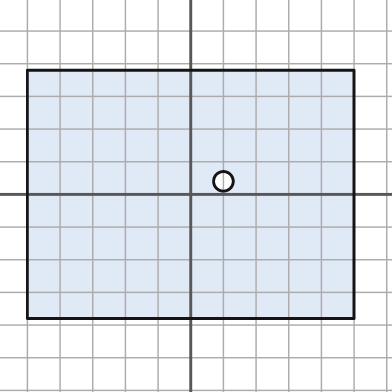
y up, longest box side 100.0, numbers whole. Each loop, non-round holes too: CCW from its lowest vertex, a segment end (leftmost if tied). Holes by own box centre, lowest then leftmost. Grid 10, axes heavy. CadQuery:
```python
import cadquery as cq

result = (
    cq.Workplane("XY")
    .moveTo(-50.0, -38.0)
    .lineTo(50.0, -38.0)
    .lineTo(50.0, 38.0)
    .lineTo(-50.0, 38.0)
    .close()
    .moveTo(10.0, 4.0)
    .circle(3.0)
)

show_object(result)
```